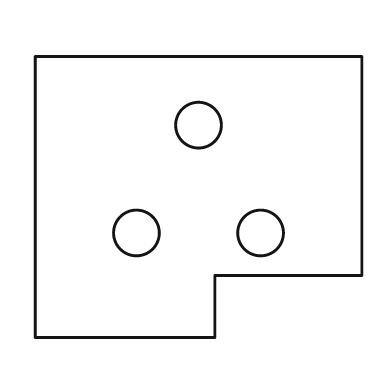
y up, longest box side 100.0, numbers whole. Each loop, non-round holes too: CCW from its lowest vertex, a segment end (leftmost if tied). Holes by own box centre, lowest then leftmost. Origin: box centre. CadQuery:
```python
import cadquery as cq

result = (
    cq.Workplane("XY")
    .moveTo(-50.0, -43.0)
    .lineTo(5.0, -43.0)
    .lineTo(5.0, -24.0)
    .lineTo(50.0, -24.0)
    .lineTo(50.0, 43.0)
    .lineTo(-50.0, 43.0)
    .close()
    .moveTo(-19.0, -11.0)
    .circle(7.0)
    .moveTo(19.0, -11.0)
    .circle(7.0)
    .moveTo(0.0, 22.0)
    .circle(7.0)
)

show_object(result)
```